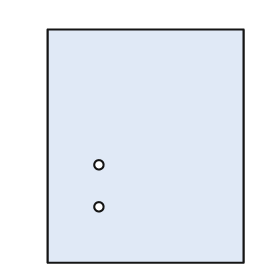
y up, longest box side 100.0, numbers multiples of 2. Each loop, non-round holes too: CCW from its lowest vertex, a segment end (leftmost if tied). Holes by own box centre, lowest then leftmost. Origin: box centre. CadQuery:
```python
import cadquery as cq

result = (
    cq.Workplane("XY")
    .moveTo(-42.0, -50.0)
    .lineTo(42.0, -50.0)
    .lineTo(42.0, 50.0)
    .lineTo(-42.0, 50.0)
    .close()
    .moveTo(-20.0, -26.0)
    .circle(2.0)
    .moveTo(-20.0, -8.0)
    .circle(2.0)
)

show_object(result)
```